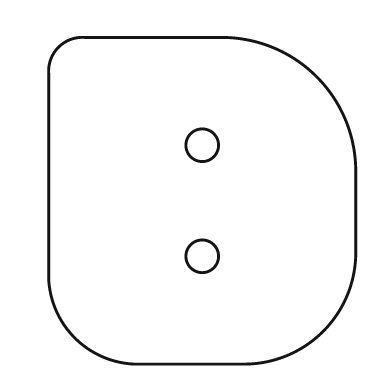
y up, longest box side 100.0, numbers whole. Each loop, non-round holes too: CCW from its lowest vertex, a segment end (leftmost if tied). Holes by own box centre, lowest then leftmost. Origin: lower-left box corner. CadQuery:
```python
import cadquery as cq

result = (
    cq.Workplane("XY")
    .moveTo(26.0, 0.0)
    .lineTo(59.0, 0.0)
    .threePointArc((84.0, 10.0), (94.0, 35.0))
    .lineTo(94.0, 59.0)
    .threePointArc((82.0, 88.0), (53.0, 100.0))
    .lineTo(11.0, 100.0)
    .threePointArc((3.0, 97.0), (0.0, 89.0))
    .lineTo(0.0, 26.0)
    .threePointArc((8.0, 8.0), (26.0, 0.0))
    .close()
    .moveTo(47.0, 33.0)
    .circle(5.0)
    .moveTo(47.0, 67.0)
    .circle(5.0)
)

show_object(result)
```